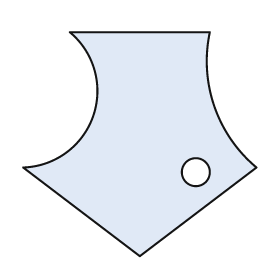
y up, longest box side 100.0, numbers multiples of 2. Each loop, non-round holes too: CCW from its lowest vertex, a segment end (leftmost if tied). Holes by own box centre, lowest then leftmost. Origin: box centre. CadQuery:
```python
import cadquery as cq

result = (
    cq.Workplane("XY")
    .moveTo(0.0, -48.0)
    .lineTo(50.0, -10.0)
    .threePointArc((32.0, 16.0), (30.0, 48.0))
    .lineTo(-30.0, 48.0)
    .threePointArc((-20.0, 12.0), (-50.0, -10.0))
    .close()
    .moveTo(24.0, -12.0)
    .circle(6.0)
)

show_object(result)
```